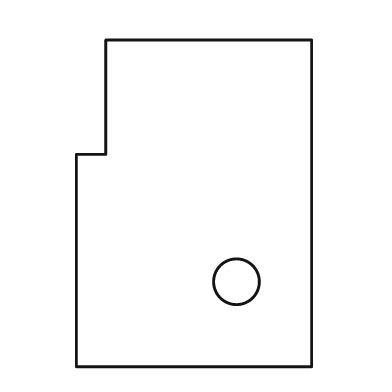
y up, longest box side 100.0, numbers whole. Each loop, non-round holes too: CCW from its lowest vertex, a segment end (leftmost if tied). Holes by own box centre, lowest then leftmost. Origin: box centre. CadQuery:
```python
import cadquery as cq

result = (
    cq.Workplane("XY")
    .moveTo(-36.0, -50.0)
    .lineTo(36.0, -50.0)
    .lineTo(36.0, 50.0)
    .lineTo(-27.0, 50.0)
    .lineTo(-27.0, 15.0)
    .lineTo(-36.0, 15.0)
    .close()
    .moveTo(13.0, -24.0)
    .circle(7.0)
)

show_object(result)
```